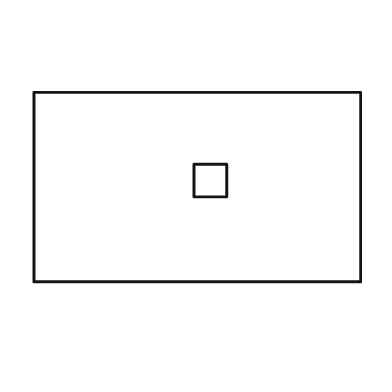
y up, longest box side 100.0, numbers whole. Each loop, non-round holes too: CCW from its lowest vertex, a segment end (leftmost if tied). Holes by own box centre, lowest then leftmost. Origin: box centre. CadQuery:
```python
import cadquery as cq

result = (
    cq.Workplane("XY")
    .moveTo(-50.0, -29.0)
    .lineTo(50.0, -29.0)
    .lineTo(50.0, 29.0)
    .lineTo(-50.0, 29.0)
    .close()
    .moveTo(-1.0, -3.0)
    .lineTo(9.0, -3.0)
    .lineTo(9.0, 7.0)
    .lineTo(-1.0, 7.0)
    .close()
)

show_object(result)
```